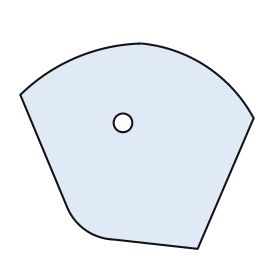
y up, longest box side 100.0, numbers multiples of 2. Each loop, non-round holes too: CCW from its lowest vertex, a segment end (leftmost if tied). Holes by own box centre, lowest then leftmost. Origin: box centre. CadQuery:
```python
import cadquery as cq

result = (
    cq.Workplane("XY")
    .moveTo(26.0, -44.0)
    .lineTo(50.0, 12.0)
    .threePointArc((30.0, 34.0), (2.0, 44.0))
    .threePointArc((-26.0, 38.0), (-50.0, 22.0))
    .lineTo(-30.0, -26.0)
    .threePointArc((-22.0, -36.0), (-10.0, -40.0))
    .close()
    .moveTo(-6.0, 10.0)
    .circle(4.0)
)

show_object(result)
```